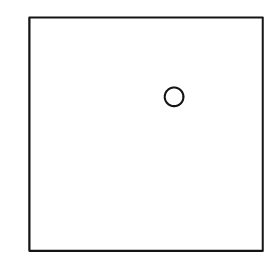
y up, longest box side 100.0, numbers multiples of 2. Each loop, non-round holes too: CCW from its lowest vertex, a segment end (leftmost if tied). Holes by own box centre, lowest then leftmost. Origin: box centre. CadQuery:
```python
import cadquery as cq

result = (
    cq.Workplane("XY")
    .moveTo(-50.0, -50.0)
    .lineTo(50.0, -50.0)
    .lineTo(50.0, 50.0)
    .lineTo(-50.0, 50.0)
    .close()
    .moveTo(12.0, 16.0)
    .circle(4.0)
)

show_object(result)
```